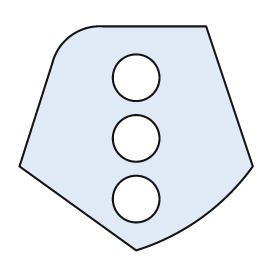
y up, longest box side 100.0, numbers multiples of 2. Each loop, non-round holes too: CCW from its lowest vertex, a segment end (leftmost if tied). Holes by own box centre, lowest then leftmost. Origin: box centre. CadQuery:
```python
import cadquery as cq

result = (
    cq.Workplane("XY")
    .moveTo(0.0, -48.0)
    .threePointArc((28.0, -34.0), (50.0, -12.0))
    .lineTo(30.0, 48.0)
    .lineTo(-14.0, 48.0)
    .threePointArc((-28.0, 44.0), (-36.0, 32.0))
    .lineTo(-50.0, -12.0)
    .close()
    .moveTo(0.0, -26.0)
    .circle(10.0)
    .moveTo(0.0, 0.0)
    .circle(10.0)
    .moveTo(0.0, 26.0)
    .circle(10.0)
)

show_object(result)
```